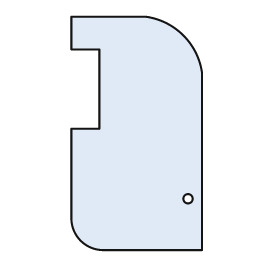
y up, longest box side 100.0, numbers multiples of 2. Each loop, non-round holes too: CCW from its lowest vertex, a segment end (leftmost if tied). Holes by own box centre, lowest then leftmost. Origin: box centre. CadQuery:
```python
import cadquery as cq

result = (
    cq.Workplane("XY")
    .moveTo(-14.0, -50.0)
    .lineTo(28.0, -50.0)
    .lineTo(28.0, 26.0)
    .threePointArc((20.0, 42.0), (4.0, 50.0))
    .lineTo(-28.0, 50.0)
    .lineTo(-28.0, 36.0)
    .lineTo(-16.0, 36.0)
    .lineTo(-16.0, 2.0)
    .lineTo(-28.0, 2.0)
    .lineTo(-28.0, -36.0)
    .threePointArc((-24.0, -46.0), (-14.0, -50.0))
    .close()
    .moveTo(22.0, -28.0)
    .circle(2.0)
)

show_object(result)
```